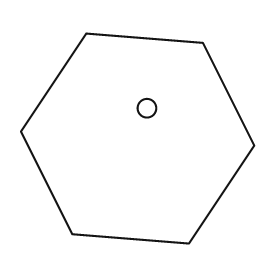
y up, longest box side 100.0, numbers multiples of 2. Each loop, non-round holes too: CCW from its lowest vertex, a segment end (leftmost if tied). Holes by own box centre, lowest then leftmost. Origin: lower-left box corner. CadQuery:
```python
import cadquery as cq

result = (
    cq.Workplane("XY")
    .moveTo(72.0, 0.0)
    .lineTo(100.0, 42.0)
    .lineTo(78.0, 86.0)
    .lineTo(28.0, 90.0)
    .lineTo(0.0, 48.0)
    .lineTo(22.0, 4.0)
    .close()
    .moveTo(54.0, 58.0)
    .circle(4.0)
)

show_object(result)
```